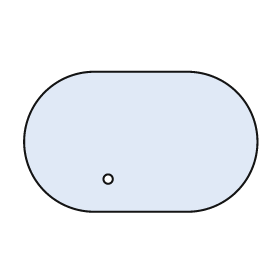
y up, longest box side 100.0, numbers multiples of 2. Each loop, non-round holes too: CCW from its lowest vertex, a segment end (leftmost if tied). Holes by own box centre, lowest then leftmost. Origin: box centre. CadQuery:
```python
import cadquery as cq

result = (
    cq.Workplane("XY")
    .moveTo(-20.0, -30.0)
    .lineTo(20.0, -30.0)
    .threePointArc((50.0, 0.0), (20.0, 30.0))
    .lineTo(-20.0, 30.0)
    .threePointArc((-50.0, 0.0), (-20.0, -30.0))
    .close()
    .moveTo(-14.0, -16.0)
    .circle(2.0)
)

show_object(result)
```